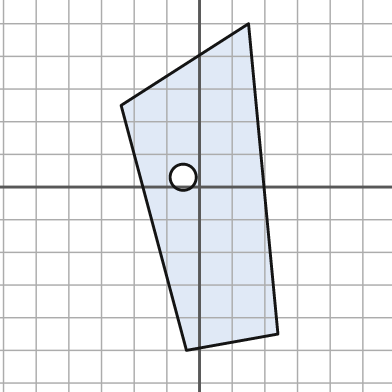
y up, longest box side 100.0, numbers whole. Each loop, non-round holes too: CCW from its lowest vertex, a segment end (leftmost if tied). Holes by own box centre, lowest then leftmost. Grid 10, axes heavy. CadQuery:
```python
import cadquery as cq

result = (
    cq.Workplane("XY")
    .moveTo(-4.0, -50.0)
    .lineTo(24.0, -45.0)
    .lineTo(15.0, 50.0)
    .lineTo(-24.0, 25.0)
    .close()
    .moveTo(-5.0, 3.0)
    .circle(4.0)
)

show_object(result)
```